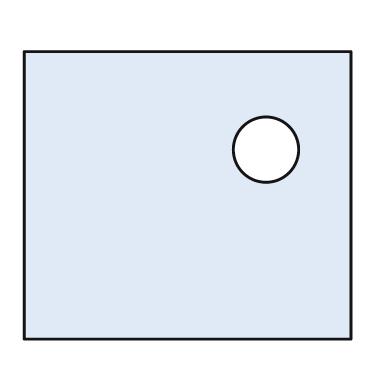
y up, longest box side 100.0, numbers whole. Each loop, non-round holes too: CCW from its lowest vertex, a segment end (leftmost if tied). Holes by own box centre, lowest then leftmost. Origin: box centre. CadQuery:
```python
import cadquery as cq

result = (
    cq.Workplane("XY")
    .moveTo(-50.0, -44.0)
    .lineTo(50.0, -44.0)
    .lineTo(50.0, 44.0)
    .lineTo(-50.0, 44.0)
    .close()
    .moveTo(24.0, 14.0)
    .circle(10.0)
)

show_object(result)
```